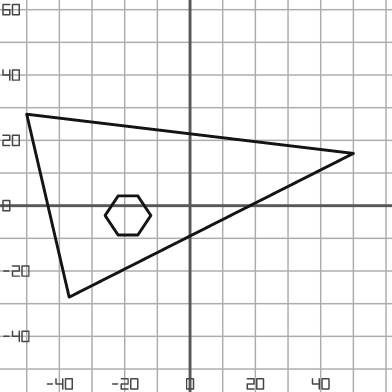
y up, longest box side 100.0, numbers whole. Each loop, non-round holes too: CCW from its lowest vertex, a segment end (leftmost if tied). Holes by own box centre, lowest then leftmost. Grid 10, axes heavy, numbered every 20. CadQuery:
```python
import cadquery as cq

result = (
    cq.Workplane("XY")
    .moveTo(-37.0, -28.0)
    .lineTo(50.0, 16.0)
    .lineTo(-50.0, 28.0)
    .close()
    .moveTo(-22.0, -9.0)
    .lineTo(-16.0, -9.0)
    .lineTo(-12.0, -3.0)
    .lineTo(-16.0, 3.0)
    .lineTo(-22.0, 3.0)
    .lineTo(-26.0, -3.0)
    .close()
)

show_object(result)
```